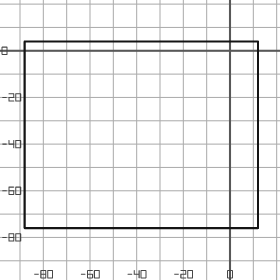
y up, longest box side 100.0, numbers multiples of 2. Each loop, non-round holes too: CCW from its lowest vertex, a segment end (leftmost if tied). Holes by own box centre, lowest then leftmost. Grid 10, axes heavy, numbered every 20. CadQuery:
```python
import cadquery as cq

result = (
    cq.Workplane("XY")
    .moveTo(-88.0, -76.0)
    .lineTo(12.0, -76.0)
    .lineTo(12.0, 4.0)
    .lineTo(-88.0, 4.0)
    .close()
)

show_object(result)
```